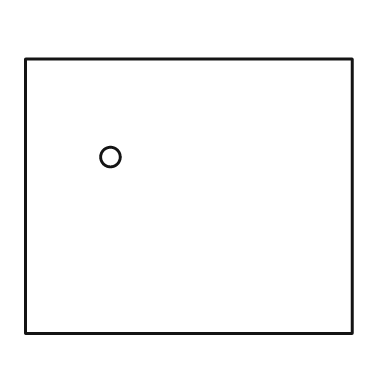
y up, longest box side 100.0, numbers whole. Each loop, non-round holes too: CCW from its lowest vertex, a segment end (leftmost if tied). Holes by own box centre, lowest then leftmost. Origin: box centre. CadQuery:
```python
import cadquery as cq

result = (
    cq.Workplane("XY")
    .moveTo(-50.0, -42.0)
    .lineTo(50.0, -42.0)
    .lineTo(50.0, 42.0)
    .lineTo(-50.0, 42.0)
    .close()
    .moveTo(-24.0, 12.0)
    .circle(3.0)
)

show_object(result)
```